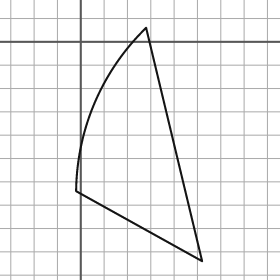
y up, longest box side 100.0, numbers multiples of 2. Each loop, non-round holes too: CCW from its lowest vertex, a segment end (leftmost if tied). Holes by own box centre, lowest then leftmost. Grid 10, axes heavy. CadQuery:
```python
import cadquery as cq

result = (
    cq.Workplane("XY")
    .moveTo(52.0, -94.0)
    .lineTo(28.0, 6.0)
    .threePointArc((6.0, -26.0), (-2.0, -64.0))
    .close()
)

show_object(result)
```